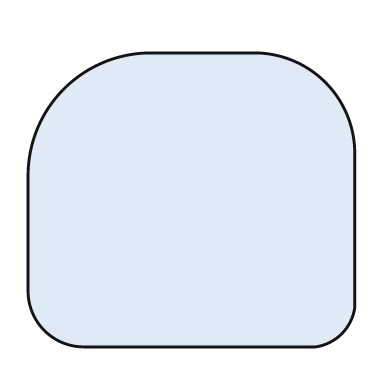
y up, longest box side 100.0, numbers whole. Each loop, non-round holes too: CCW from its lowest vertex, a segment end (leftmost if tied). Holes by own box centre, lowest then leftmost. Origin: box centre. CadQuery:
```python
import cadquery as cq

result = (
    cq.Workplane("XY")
    .moveTo(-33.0, -45.0)
    .lineTo(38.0, -45.0)
    .threePointArc((46.0, -41.0), (50.0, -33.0))
    .lineTo(50.0, 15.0)
    .threePointArc((41.0, 36.0), (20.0, 45.0))
    .lineTo(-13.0, 45.0)
    .threePointArc((-39.0, 34.0), (-50.0, 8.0))
    .lineTo(-50.0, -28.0)
    .threePointArc((-45.0, -40.0), (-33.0, -45.0))
    .close()
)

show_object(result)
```